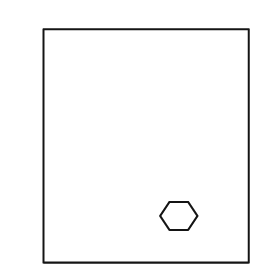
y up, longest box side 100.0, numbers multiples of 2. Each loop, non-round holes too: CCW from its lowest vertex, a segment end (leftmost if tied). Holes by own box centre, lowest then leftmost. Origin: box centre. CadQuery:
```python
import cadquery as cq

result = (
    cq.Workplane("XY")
    .moveTo(-44.0, -50.0)
    .lineTo(44.0, -50.0)
    .lineTo(44.0, 50.0)
    .lineTo(-44.0, 50.0)
    .close()
    .moveTo(10.0, -36.0)
    .lineTo(18.0, -36.0)
    .lineTo(22.0, -30.0)
    .lineTo(18.0, -24.0)
    .lineTo(10.0, -24.0)
    .lineTo(6.0, -30.0)
    .close()
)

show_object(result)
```